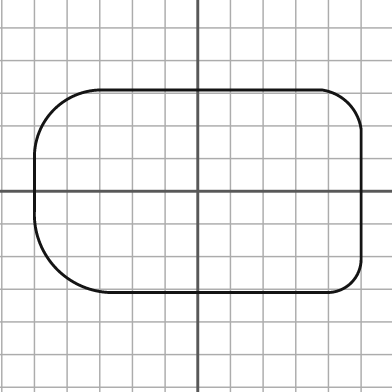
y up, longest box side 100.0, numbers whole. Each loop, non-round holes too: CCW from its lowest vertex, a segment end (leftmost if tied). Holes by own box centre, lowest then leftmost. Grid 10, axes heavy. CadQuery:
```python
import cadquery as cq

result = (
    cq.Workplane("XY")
    .moveTo(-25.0, -31.0)
    .lineTo(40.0, -31.0)
    .threePointArc((47.0, -28.0), (50.0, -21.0))
    .lineTo(50.0, 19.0)
    .threePointArc((46.0, 27.0), (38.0, 31.0))
    .lineTo(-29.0, 31.0)
    .threePointArc((-44.0, 25.0), (-50.0, 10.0))
    .lineTo(-50.0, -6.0)
    .threePointArc((-43.0, -24.0), (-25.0, -31.0))
    .close()
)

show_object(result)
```